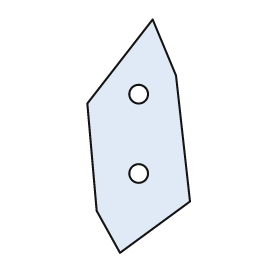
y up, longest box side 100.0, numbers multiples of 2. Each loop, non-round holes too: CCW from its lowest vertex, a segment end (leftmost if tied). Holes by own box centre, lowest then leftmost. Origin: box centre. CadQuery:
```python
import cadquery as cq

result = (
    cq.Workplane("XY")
    .moveTo(-8.0, -50.0)
    .lineTo(22.0, -28.0)
    .lineTo(16.0, 26.0)
    .lineTo(6.0, 50.0)
    .lineTo(-22.0, 14.0)
    .lineTo(-18.0, -32.0)
    .close()
    .moveTo(0.0, -16.0)
    .circle(4.0)
    .moveTo(0.0, 18.0)
    .circle(4.0)
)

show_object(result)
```